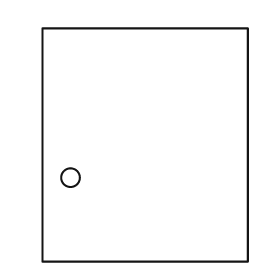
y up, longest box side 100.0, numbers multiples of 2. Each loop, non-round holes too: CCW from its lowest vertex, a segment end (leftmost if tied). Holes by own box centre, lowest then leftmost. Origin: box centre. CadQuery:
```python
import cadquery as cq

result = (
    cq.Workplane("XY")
    .moveTo(-44.0, -50.0)
    .lineTo(44.0, -50.0)
    .lineTo(44.0, 50.0)
    .lineTo(-44.0, 50.0)
    .close()
    .moveTo(-32.0, -14.0)
    .circle(4.0)
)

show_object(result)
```